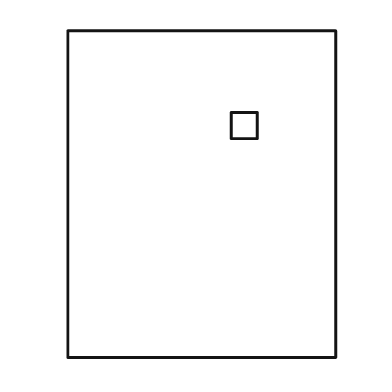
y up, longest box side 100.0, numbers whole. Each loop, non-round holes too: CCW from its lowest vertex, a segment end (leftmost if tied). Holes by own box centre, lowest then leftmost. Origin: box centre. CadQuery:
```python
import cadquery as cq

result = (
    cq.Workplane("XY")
    .moveTo(-41.0, -50.0)
    .lineTo(41.0, -50.0)
    .lineTo(41.0, 50.0)
    .lineTo(-41.0, 50.0)
    .close()
    .moveTo(9.0, 17.0)
    .lineTo(17.0, 17.0)
    .lineTo(17.0, 25.0)
    .lineTo(9.0, 25.0)
    .close()
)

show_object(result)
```